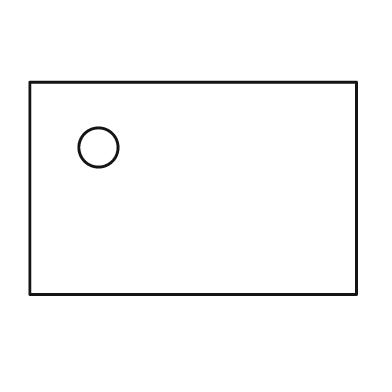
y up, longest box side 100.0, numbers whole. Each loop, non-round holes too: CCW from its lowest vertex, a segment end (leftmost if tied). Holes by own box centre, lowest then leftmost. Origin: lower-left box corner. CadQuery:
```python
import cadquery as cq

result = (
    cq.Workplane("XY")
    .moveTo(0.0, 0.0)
    .lineTo(100.0, 0.0)
    .lineTo(100.0, 65.0)
    .lineTo(0.0, 65.0)
    .close()
    .moveTo(21.0, 45.0)
    .circle(6.0)
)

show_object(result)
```